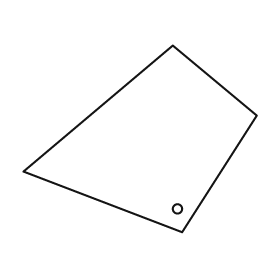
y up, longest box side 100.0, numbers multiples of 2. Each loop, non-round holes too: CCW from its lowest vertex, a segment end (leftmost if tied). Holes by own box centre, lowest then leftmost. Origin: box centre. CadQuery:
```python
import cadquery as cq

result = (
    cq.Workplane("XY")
    .moveTo(18.0, -40.0)
    .lineTo(50.0, 10.0)
    .lineTo(14.0, 40.0)
    .lineTo(-50.0, -14.0)
    .close()
    .moveTo(16.0, -30.0)
    .circle(2.0)
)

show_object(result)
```